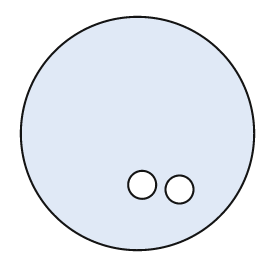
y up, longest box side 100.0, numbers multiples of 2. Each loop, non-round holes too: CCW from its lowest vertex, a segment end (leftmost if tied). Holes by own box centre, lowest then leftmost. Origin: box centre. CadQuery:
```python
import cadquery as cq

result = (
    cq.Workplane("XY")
    .moveTo(0.0, 0.0)
    .circle(50.0)
    .moveTo(18.0, -24.0)
    .circle(6.0)
    .moveTo(2.0, -22.0)
    .circle(6.0)
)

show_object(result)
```